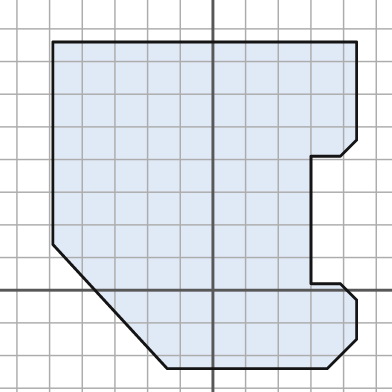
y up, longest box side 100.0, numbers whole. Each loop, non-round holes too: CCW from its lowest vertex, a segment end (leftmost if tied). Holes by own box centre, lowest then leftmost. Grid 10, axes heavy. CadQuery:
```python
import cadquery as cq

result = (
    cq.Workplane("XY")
    .moveTo(-14.0, -24.0)
    .lineTo(35.0, -24.0)
    .lineTo(44.0, -15.0)
    .lineTo(44.0, -3.0)
    .lineTo(39.0, 2.0)
    .lineTo(30.0, 2.0)
    .lineTo(30.0, 41.0)
    .lineTo(39.0, 41.0)
    .lineTo(44.0, 46.0)
    .lineTo(44.0, 76.0)
    .lineTo(-49.0, 76.0)
    .lineTo(-49.0, 14.0)
    .close()
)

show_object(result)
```